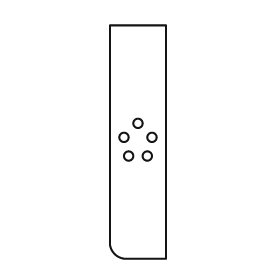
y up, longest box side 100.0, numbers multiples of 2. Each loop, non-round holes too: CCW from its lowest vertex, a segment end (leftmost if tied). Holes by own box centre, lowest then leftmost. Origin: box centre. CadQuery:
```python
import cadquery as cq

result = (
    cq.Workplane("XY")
    .moveTo(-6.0, -50.0)
    .lineTo(12.0, -50.0)
    .lineTo(12.0, 50.0)
    .lineTo(-12.0, 50.0)
    .lineTo(-12.0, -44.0)
    .threePointArc((-10.0, -48.0), (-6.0, -50.0))
    .close()
    .moveTo(-4.0, -6.0)
    .circle(2.0)
    .moveTo(4.0, -6.0)
    .circle(2.0)
    .moveTo(-6.0, 2.0)
    .circle(2.0)
    .moveTo(6.0, 2.0)
    .circle(2.0)
    .moveTo(0.0, 8.0)
    .circle(2.0)
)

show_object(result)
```